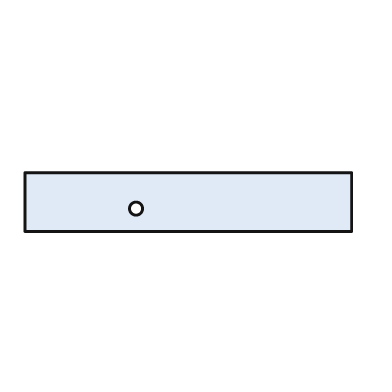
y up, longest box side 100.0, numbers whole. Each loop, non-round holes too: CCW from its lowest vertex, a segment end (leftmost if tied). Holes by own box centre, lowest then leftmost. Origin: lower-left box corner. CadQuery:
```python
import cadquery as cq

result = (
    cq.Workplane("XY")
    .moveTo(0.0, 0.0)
    .lineTo(100.0, 0.0)
    .lineTo(100.0, 18.0)
    .lineTo(0.0, 18.0)
    .close()
    .moveTo(34.0, 7.0)
    .circle(2.0)
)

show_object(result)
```